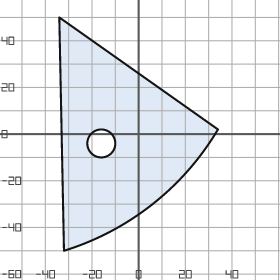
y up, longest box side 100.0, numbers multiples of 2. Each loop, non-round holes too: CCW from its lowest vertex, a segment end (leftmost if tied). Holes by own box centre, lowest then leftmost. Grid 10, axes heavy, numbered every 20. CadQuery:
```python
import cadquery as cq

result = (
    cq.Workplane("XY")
    .moveTo(-32.0, -50.0)
    .threePointArc((6.0, -30.0), (34.0, 2.0))
    .lineTo(-34.0, 50.0)
    .close()
    .moveTo(-16.0, -4.0)
    .circle(6.0)
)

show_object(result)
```